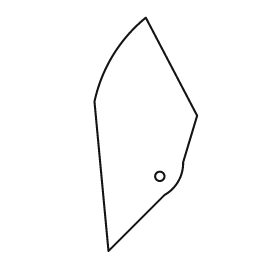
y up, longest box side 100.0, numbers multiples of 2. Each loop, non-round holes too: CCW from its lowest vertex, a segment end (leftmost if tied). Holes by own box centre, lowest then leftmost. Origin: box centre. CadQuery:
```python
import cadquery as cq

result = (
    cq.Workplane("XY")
    .moveTo(-16.0, -50.0)
    .lineTo(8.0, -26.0)
    .threePointArc((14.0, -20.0), (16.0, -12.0))
    .lineTo(22.0, 8.0)
    .lineTo(0.0, 50.0)
    .threePointArc((-14.0, 34.0), (-22.0, 14.0))
    .close()
    .moveTo(6.0, -18.0)
    .circle(2.0)
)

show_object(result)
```